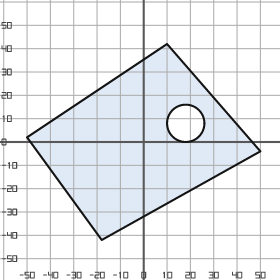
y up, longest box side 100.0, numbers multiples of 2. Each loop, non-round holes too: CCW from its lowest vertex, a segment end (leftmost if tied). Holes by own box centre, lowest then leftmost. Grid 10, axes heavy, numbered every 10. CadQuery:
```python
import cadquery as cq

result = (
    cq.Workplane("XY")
    .moveTo(-18.0, -42.0)
    .lineTo(50.0, -4.0)
    .lineTo(10.0, 42.0)
    .lineTo(-50.0, 2.0)
    .close()
    .moveTo(18.0, 8.0)
    .circle(8.0)
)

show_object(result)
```